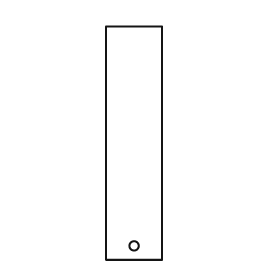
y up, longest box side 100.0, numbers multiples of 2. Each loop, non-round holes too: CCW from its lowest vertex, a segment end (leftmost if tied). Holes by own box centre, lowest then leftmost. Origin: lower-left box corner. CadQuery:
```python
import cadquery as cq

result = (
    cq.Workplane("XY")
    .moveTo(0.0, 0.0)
    .lineTo(24.0, 0.0)
    .lineTo(24.0, 100.0)
    .lineTo(0.0, 100.0)
    .close()
    .moveTo(12.0, 6.0)
    .circle(2.0)
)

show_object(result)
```